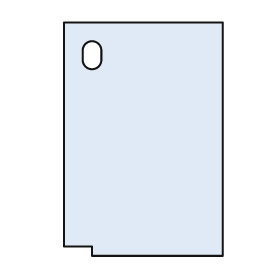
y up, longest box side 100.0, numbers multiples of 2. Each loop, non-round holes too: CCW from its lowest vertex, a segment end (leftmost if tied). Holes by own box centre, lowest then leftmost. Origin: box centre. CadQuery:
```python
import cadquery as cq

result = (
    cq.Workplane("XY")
    .moveTo(-22.0, -50.0)
    .lineTo(34.0, -50.0)
    .lineTo(34.0, 50.0)
    .lineTo(-34.0, 50.0)
    .lineTo(-34.0, -46.0)
    .lineTo(-22.0, -46.0)
    .close()
    .moveTo(-26.0, 34.0)
    .threePointArc((-22.0, 30.0), (-18.0, 34.0))
    .lineTo(-18.0, 38.0)
    .threePointArc((-22.0, 42.0), (-26.0, 38.0))
    .close()
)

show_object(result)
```